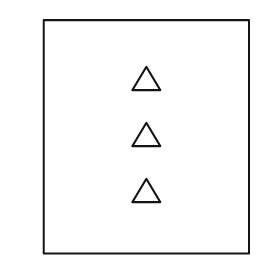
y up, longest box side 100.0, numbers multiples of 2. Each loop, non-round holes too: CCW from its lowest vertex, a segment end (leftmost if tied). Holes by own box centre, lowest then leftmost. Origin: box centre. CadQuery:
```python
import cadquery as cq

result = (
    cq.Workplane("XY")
    .moveTo(-44.0, -50.0)
    .lineTo(44.0, -50.0)
    .lineTo(44.0, 50.0)
    .lineTo(-44.0, 50.0)
    .close()
    .moveTo(-6.0, -28.0)
    .lineTo(6.0, -28.0)
    .lineTo(0.0, -18.0)
    .close()
    .moveTo(-6.0, -4.0)
    .lineTo(6.0, -4.0)
    .lineTo(0.0, 6.0)
    .close()
    .moveTo(-6.0, 20.0)
    .lineTo(6.0, 20.0)
    .lineTo(0.0, 30.0)
    .close()
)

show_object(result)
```